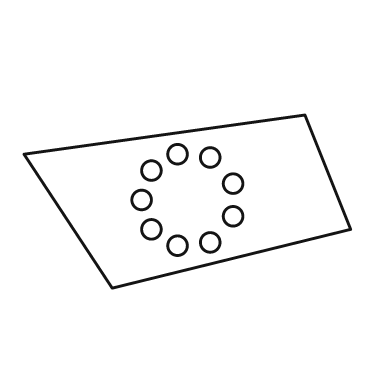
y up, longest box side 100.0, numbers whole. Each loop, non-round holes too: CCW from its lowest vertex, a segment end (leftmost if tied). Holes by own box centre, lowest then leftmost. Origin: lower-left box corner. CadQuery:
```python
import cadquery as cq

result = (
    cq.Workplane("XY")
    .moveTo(27.0, 0.0)
    .lineTo(100.0, 18.0)
    .lineTo(86.0, 53.0)
    .lineTo(0.0, 41.0)
    .close()
    .moveTo(47.0, 13.0)
    .circle(3.0)
    .moveTo(57.0, 14.0)
    .circle(3.0)
    .moveTo(39.0, 18.0)
    .circle(3.0)
    .moveTo(64.0, 22.0)
    .circle(3.0)
    .moveTo(36.0, 27.0)
    .circle(3.0)
    .moveTo(64.0, 32.0)
    .circle(3.0)
    .moveTo(39.0, 36.0)
    .circle(3.0)
    .moveTo(57.0, 40.0)
    .circle(3.0)
    .moveTo(47.0, 41.0)
    .circle(3.0)
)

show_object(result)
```